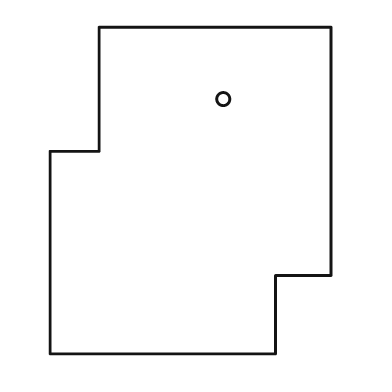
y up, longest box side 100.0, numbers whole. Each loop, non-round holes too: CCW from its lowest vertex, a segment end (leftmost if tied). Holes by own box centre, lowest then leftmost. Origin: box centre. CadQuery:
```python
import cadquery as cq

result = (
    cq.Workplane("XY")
    .moveTo(-43.0, -50.0)
    .lineTo(26.0, -50.0)
    .lineTo(26.0, -26.0)
    .lineTo(43.0, -26.0)
    .lineTo(43.0, 50.0)
    .lineTo(-28.0, 50.0)
    .lineTo(-28.0, 12.0)
    .lineTo(-43.0, 12.0)
    .close()
    .moveTo(10.0, 28.0)
    .circle(2.0)
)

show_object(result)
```